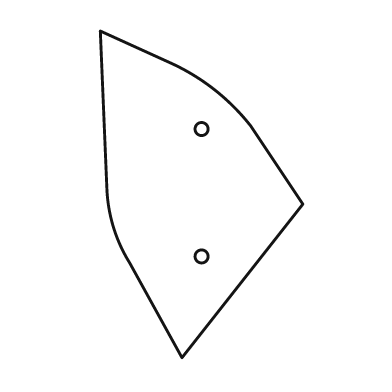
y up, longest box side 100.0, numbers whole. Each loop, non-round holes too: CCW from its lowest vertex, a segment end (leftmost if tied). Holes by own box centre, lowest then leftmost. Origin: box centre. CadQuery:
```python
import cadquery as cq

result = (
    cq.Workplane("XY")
    .moveTo(-6.0, -50.0)
    .lineTo(31.0, -3.0)
    .lineTo(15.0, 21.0)
    .threePointArc((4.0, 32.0), (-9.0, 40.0))
    .lineTo(-31.0, 50.0)
    .lineTo(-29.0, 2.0)
    .threePointArc((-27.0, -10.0), (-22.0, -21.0))
    .close()
    .moveTo(0.0, -19.0)
    .circle(2.0)
    .moveTo(0.0, 20.0)
    .circle(2.0)
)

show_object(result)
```